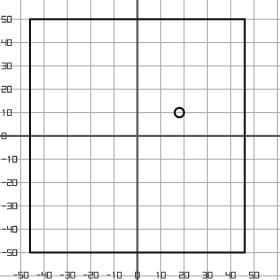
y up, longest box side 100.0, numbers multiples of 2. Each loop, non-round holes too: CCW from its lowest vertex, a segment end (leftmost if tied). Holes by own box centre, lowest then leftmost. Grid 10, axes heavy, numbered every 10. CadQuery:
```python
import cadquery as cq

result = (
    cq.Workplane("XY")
    .moveTo(-46.0, -50.0)
    .lineTo(46.0, -50.0)
    .lineTo(46.0, 50.0)
    .lineTo(-46.0, 50.0)
    .close()
    .moveTo(18.0, 10.0)
    .circle(2.0)
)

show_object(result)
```